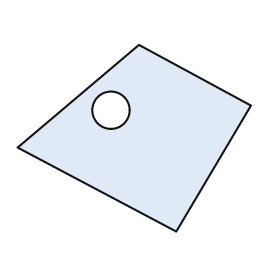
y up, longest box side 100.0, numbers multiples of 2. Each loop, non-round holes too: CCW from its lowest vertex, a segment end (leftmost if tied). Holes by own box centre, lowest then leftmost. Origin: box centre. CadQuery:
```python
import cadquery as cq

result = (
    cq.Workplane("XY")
    .moveTo(18.0, -40.0)
    .lineTo(50.0, 14.0)
    .lineTo(2.0, 40.0)
    .lineTo(-50.0, -4.0)
    .close()
    .moveTo(-10.0, 12.0)
    .circle(8.0)
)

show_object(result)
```